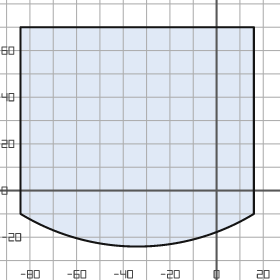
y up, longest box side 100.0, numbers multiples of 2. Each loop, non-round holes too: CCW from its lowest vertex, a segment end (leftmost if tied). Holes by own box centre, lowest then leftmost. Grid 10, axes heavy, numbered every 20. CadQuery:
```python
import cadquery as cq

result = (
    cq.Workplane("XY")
    .moveTo(-84.0, -10.0)
    .threePointArc((-34.0, -24.0), (16.0, -10.0))
    .lineTo(16.0, 70.0)
    .lineTo(-84.0, 70.0)
    .close()
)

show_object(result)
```